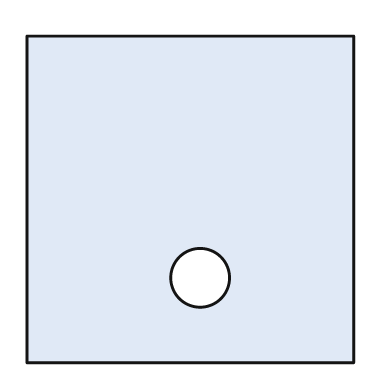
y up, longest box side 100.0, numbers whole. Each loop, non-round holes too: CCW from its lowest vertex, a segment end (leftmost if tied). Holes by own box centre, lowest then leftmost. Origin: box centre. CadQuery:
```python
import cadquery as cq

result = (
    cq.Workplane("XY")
    .moveTo(-50.0, -50.0)
    .lineTo(50.0, -50.0)
    .lineTo(50.0, 50.0)
    .lineTo(-50.0, 50.0)
    .close()
    .moveTo(3.0, -24.0)
    .circle(9.0)
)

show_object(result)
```